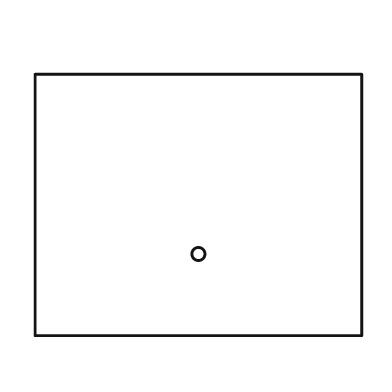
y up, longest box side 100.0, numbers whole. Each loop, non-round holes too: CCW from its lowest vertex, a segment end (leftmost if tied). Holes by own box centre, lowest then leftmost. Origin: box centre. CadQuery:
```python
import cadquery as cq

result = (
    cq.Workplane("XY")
    .moveTo(-50.0, -40.0)
    .lineTo(50.0, -40.0)
    .lineTo(50.0, 40.0)
    .lineTo(-50.0, 40.0)
    .close()
    .moveTo(0.0, -15.0)
    .circle(2.0)
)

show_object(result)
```